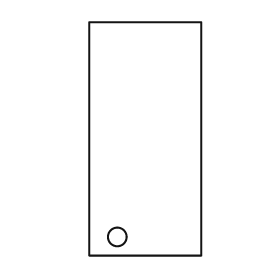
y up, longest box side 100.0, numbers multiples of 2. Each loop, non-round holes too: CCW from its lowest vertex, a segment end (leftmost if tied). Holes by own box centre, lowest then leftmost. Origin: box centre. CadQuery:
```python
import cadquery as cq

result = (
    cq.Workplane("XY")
    .moveTo(-24.0, -50.0)
    .lineTo(24.0, -50.0)
    .lineTo(24.0, 50.0)
    .lineTo(-24.0, 50.0)
    .close()
    .moveTo(-12.0, -42.0)
    .circle(4.0)
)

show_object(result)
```